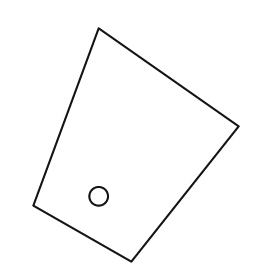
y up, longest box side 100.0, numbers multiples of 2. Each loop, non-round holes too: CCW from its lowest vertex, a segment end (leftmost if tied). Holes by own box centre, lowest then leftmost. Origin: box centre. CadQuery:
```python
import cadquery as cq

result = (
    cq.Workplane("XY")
    .moveTo(-2.0, -50.0)
    .lineTo(44.0, 8.0)
    .lineTo(-16.0, 50.0)
    .lineTo(-44.0, -26.0)
    .close()
    .moveTo(-16.0, -22.0)
    .circle(4.0)
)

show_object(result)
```